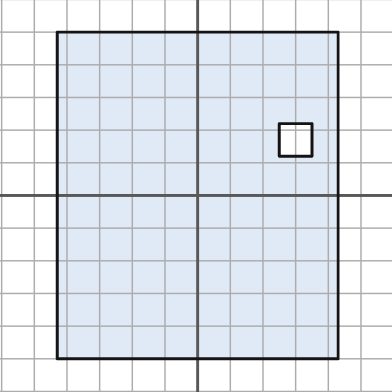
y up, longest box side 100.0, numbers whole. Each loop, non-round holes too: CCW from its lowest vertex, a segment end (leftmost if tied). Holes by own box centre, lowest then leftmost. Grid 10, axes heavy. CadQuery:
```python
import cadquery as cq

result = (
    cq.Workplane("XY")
    .moveTo(-43.0, -50.0)
    .lineTo(43.0, -50.0)
    .lineTo(43.0, 50.0)
    .lineTo(-43.0, 50.0)
    .close()
    .moveTo(25.0, 12.0)
    .lineTo(35.0, 12.0)
    .lineTo(35.0, 22.0)
    .lineTo(25.0, 22.0)
    .close()
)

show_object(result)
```